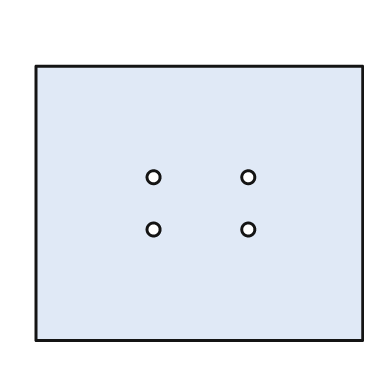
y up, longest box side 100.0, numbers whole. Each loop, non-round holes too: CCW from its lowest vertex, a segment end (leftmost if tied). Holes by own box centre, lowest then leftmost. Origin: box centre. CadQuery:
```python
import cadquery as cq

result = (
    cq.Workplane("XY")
    .moveTo(-50.0, -42.0)
    .lineTo(50.0, -42.0)
    .lineTo(50.0, 42.0)
    .lineTo(-50.0, 42.0)
    .close()
    .moveTo(-14.0, -8.0)
    .circle(2.0)
    .moveTo(15.0, -8.0)
    .circle(2.0)
    .moveTo(-14.0, 8.0)
    .circle(2.0)
    .moveTo(15.0, 8.0)
    .circle(2.0)
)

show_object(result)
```